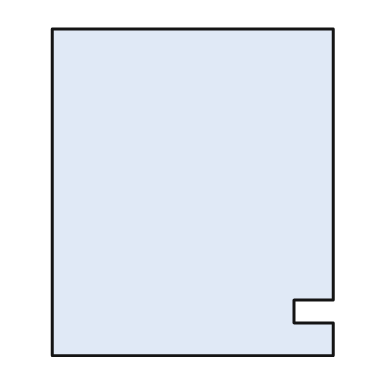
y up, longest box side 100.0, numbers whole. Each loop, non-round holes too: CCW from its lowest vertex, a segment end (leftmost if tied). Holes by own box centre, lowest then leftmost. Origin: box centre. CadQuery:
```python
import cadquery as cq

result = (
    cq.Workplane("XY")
    .moveTo(-43.0, -50.0)
    .lineTo(43.0, -50.0)
    .lineTo(43.0, -40.0)
    .lineTo(31.0, -40.0)
    .lineTo(31.0, -33.0)
    .lineTo(43.0, -33.0)
    .lineTo(43.0, 50.0)
    .lineTo(-43.0, 50.0)
    .close()
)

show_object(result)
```